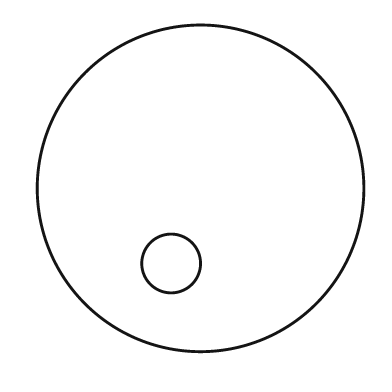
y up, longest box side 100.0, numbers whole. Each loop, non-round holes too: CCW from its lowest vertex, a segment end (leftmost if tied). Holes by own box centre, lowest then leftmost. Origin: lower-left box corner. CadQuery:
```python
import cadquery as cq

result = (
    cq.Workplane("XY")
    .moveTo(50.0, 50.0)
    .circle(50.0)
    .moveTo(41.0, 27.0)
    .circle(9.0)
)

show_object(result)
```